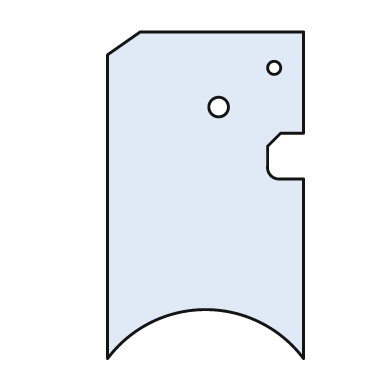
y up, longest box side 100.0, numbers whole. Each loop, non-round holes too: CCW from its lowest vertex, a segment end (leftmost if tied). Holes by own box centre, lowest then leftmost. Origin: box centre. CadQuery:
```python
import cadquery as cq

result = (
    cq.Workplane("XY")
    .moveTo(-30.0, -50.0)
    .threePointArc((0.0, -35.0), (30.0, -50.0))
    .lineTo(30.0, 5.0)
    .lineTo(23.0, 5.0)
    .threePointArc((20.0, 6.0), (19.0, 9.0))
    .lineTo(19.0, 15.0)
    .lineTo(23.0, 19.0)
    .lineTo(30.0, 19.0)
    .lineTo(30.0, 50.0)
    .lineTo(-20.0, 50.0)
    .lineTo(-30.0, 43.0)
    .close()
    .moveTo(4.0, 27.0)
    .circle(3.0)
    .moveTo(21.0, 39.0)
    .circle(2.0)
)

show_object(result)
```